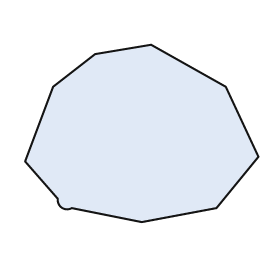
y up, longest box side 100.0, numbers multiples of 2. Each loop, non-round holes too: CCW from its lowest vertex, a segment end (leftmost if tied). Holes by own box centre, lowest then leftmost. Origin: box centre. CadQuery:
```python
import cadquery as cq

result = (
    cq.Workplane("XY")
    .moveTo(0.0, -38.0)
    .lineTo(32.0, -32.0)
    .lineTo(50.0, -10.0)
    .lineTo(36.0, 20.0)
    .lineTo(4.0, 38.0)
    .lineTo(-20.0, 34.0)
    .lineTo(-38.0, 20.0)
    .lineTo(-50.0, -12.0)
    .lineTo(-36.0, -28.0)
    .threePointArc((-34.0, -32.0), (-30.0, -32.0))
    .close()
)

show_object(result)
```